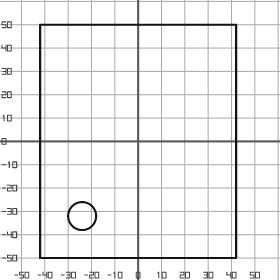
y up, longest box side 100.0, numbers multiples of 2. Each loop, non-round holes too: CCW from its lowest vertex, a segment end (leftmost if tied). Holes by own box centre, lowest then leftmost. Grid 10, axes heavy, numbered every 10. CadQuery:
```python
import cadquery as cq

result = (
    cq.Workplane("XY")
    .moveTo(-42.0, -50.0)
    .lineTo(42.0, -50.0)
    .lineTo(42.0, 50.0)
    .lineTo(-42.0, 50.0)
    .close()
    .moveTo(-24.0, -32.0)
    .circle(6.0)
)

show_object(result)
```